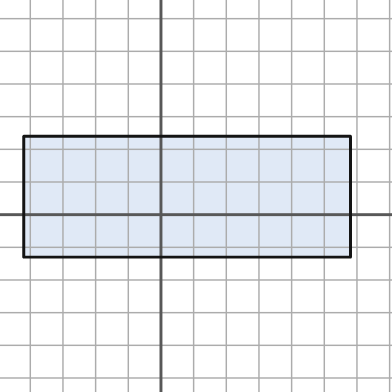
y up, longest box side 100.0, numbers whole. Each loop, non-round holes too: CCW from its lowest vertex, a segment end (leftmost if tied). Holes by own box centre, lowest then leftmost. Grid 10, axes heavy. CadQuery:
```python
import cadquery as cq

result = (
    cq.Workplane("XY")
    .moveTo(-42.0, -13.0)
    .lineTo(58.0, -13.0)
    .lineTo(58.0, 24.0)
    .lineTo(-42.0, 24.0)
    .close()
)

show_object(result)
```